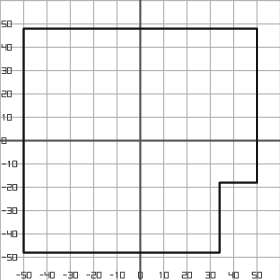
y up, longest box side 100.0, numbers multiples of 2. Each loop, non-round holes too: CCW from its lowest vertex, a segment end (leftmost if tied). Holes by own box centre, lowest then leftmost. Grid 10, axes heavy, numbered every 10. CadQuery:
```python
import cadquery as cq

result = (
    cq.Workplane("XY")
    .moveTo(-50.0, -48.0)
    .lineTo(34.0, -48.0)
    .lineTo(34.0, -18.0)
    .lineTo(50.0, -18.0)
    .lineTo(50.0, 48.0)
    .lineTo(-50.0, 48.0)
    .close()
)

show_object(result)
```